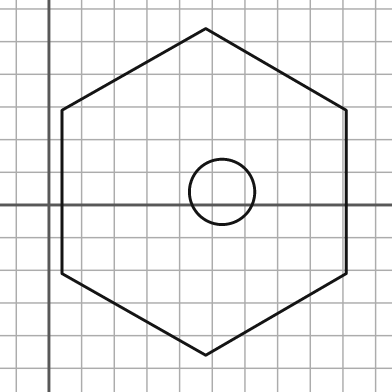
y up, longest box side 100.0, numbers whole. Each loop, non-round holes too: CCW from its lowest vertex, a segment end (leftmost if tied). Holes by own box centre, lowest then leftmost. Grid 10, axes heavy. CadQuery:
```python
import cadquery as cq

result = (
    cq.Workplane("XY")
    .moveTo(48.0, -46.0)
    .lineTo(91.0, -21.0)
    .lineTo(91.0, 29.0)
    .lineTo(48.0, 54.0)
    .lineTo(4.0, 29.0)
    .lineTo(4.0, -21.0)
    .close()
    .moveTo(53.0, 4.0)
    .circle(10.0)
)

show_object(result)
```